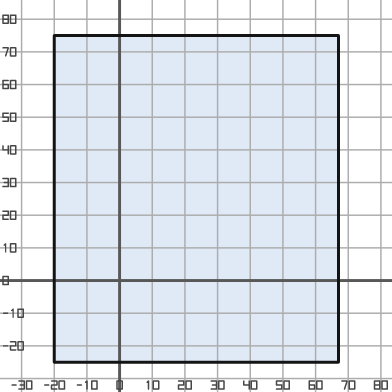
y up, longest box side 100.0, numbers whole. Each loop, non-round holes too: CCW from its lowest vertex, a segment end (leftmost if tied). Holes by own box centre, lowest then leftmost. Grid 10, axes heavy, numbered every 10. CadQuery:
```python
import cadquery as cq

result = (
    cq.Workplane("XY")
    .moveTo(-20.0, -25.0)
    .lineTo(67.0, -25.0)
    .lineTo(67.0, 75.0)
    .lineTo(-20.0, 75.0)
    .close()
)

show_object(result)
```